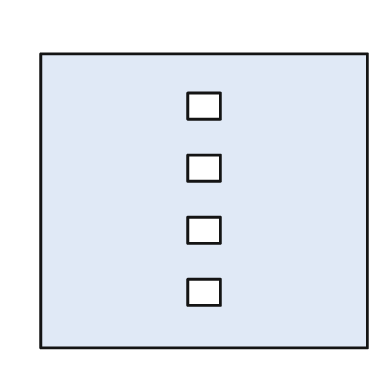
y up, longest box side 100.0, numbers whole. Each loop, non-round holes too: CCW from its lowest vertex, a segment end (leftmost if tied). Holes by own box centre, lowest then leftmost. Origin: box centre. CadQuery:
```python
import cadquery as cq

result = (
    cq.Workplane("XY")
    .moveTo(-50.0, -45.0)
    .lineTo(50.0, -45.0)
    .lineTo(50.0, 45.0)
    .lineTo(-50.0, 45.0)
    .close()
    .moveTo(-5.0, -32.0)
    .lineTo(5.0, -32.0)
    .lineTo(5.0, -24.0)
    .lineTo(-5.0, -24.0)
    .close()
    .moveTo(-5.0, -13.0)
    .lineTo(5.0, -13.0)
    .lineTo(5.0, -5.0)
    .lineTo(-5.0, -5.0)
    .close()
    .moveTo(-5.0, 6.0)
    .lineTo(5.0, 6.0)
    .lineTo(5.0, 14.0)
    .lineTo(-5.0, 14.0)
    .close()
    .moveTo(-5.0, 25.0)
    .lineTo(5.0, 25.0)
    .lineTo(5.0, 33.0)
    .lineTo(-5.0, 33.0)
    .close()
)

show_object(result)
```